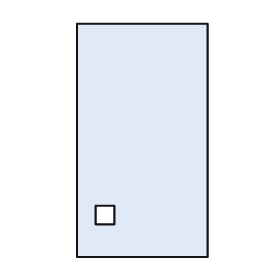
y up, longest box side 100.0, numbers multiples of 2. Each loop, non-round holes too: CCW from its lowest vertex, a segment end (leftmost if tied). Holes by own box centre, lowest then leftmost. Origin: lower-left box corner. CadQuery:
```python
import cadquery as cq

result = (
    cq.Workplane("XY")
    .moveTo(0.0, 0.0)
    .lineTo(56.0, 0.0)
    .lineTo(56.0, 100.0)
    .lineTo(0.0, 100.0)
    .close()
    .moveTo(8.0, 14.0)
    .lineTo(16.0, 14.0)
    .lineTo(16.0, 22.0)
    .lineTo(8.0, 22.0)
    .close()
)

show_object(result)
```